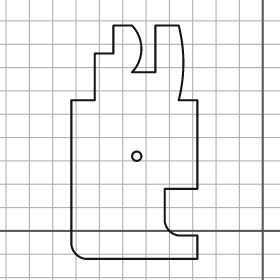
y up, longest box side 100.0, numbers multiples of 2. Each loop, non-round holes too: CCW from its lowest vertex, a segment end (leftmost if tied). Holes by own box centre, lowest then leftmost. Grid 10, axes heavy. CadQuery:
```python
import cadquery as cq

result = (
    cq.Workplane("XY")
    .moveTo(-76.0, -12.0)
    .lineTo(-28.0, -12.0)
    .lineTo(-28.0, -2.0)
    .lineTo(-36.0, -2.0)
    .threePointArc((-40.0, 0.0), (-42.0, 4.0))
    .lineTo(-42.0, 18.0)
    .lineTo(-28.0, 18.0)
    .lineTo(-28.0, 56.0)
    .lineTo(-36.0, 56.0)
    .threePointArc((-34.0, 72.0), (-36.0, 88.0))
    .lineTo(-46.0, 88.0)
    .lineTo(-46.0, 68.0)
    .lineTo(-56.0, 68.0)
    .threePointArc((-52.0, 78.0), (-56.0, 88.0))
    .lineTo(-64.0, 88.0)
    .lineTo(-64.0, 76.0)
    .lineTo(-72.0, 76.0)
    .lineTo(-72.0, 56.0)
    .lineTo(-82.0, 56.0)
    .lineTo(-82.0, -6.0)
    .threePointArc((-80.0, -10.0), (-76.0, -12.0))
    .close()
    .moveTo(-54.0, 32.0)
    .circle(2.0)
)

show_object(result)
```